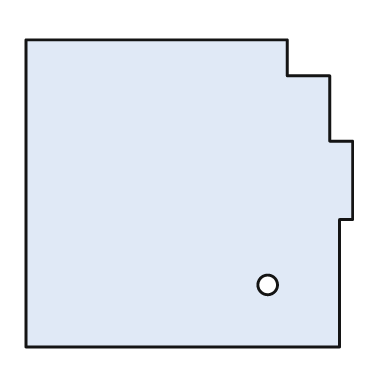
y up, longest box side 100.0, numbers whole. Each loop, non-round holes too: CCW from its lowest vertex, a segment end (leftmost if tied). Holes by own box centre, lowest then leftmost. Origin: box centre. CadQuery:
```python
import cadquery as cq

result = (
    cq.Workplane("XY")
    .moveTo(-50.0, -47.0)
    .lineTo(46.0, -47.0)
    .lineTo(46.0, -8.0)
    .lineTo(50.0, -8.0)
    .lineTo(50.0, 16.0)
    .lineTo(43.0, 16.0)
    .lineTo(43.0, 36.0)
    .lineTo(30.0, 36.0)
    .lineTo(30.0, 47.0)
    .lineTo(-50.0, 47.0)
    .close()
    .moveTo(24.0, -28.0)
    .circle(3.0)
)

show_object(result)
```